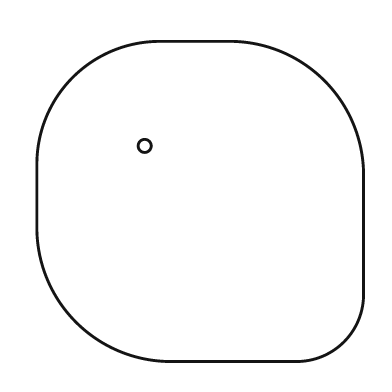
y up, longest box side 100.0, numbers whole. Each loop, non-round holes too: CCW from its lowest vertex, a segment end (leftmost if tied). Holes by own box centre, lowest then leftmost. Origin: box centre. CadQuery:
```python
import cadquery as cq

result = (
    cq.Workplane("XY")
    .moveTo(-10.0, -49.0)
    .lineTo(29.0, -49.0)
    .threePointArc((44.0, -43.0), (50.0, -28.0))
    .lineTo(50.0, 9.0)
    .threePointArc((38.0, 37.0), (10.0, 49.0))
    .lineTo(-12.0, 49.0)
    .threePointArc((-39.0, 38.0), (-50.0, 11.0))
    .lineTo(-50.0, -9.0)
    .threePointArc((-38.0, -37.0), (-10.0, -49.0))
    .close()
    .moveTo(-17.0, 17.0)
    .circle(2.0)
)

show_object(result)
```